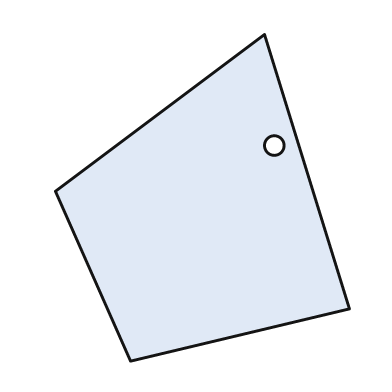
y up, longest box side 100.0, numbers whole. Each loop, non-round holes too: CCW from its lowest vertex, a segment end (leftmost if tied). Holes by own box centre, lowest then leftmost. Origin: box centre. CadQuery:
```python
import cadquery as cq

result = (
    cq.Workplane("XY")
    .moveTo(-22.0, -50.0)
    .lineTo(45.0, -34.0)
    .lineTo(19.0, 50.0)
    .lineTo(-45.0, 2.0)
    .close()
    .moveTo(22.0, 16.0)
    .circle(3.0)
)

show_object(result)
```